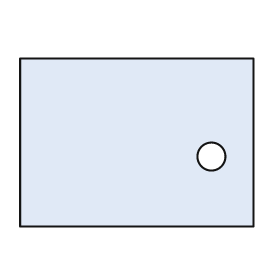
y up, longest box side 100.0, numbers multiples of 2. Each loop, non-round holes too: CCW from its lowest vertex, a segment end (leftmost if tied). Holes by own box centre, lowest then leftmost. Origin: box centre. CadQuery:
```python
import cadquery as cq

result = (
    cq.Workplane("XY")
    .moveTo(-50.0, -36.0)
    .lineTo(50.0, -36.0)
    .lineTo(50.0, 36.0)
    .lineTo(-50.0, 36.0)
    .close()
    .moveTo(32.0, -6.0)
    .circle(6.0)
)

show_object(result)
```